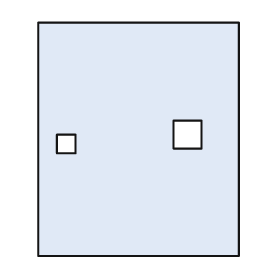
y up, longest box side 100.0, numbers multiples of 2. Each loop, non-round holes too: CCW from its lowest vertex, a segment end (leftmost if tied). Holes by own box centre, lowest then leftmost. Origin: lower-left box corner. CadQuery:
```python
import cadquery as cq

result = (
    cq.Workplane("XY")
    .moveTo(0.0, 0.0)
    .lineTo(86.0, 0.0)
    .lineTo(86.0, 100.0)
    .lineTo(0.0, 100.0)
    .close()
    .moveTo(8.0, 44.0)
    .lineTo(16.0, 44.0)
    .lineTo(16.0, 52.0)
    .lineTo(8.0, 52.0)
    .close()
    .moveTo(58.0, 46.0)
    .lineTo(70.0, 46.0)
    .lineTo(70.0, 58.0)
    .lineTo(58.0, 58.0)
    .close()
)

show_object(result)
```